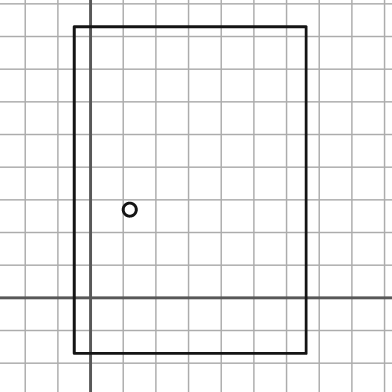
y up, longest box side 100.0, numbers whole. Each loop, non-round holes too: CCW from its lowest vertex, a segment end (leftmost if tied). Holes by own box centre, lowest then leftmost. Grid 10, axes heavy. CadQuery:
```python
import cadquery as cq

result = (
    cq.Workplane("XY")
    .moveTo(-5.0, -17.0)
    .lineTo(66.0, -17.0)
    .lineTo(66.0, 83.0)
    .lineTo(-5.0, 83.0)
    .close()
    .moveTo(12.0, 27.0)
    .circle(2.0)
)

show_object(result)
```